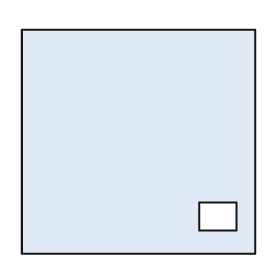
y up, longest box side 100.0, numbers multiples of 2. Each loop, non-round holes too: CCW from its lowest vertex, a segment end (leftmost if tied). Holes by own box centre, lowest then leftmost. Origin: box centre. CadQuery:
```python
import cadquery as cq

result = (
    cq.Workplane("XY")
    .moveTo(-50.0, -48.0)
    .lineTo(50.0, -48.0)
    .lineTo(50.0, 48.0)
    .lineTo(-50.0, 48.0)
    .close()
    .moveTo(26.0, -38.0)
    .lineTo(42.0, -38.0)
    .lineTo(42.0, -26.0)
    .lineTo(26.0, -26.0)
    .close()
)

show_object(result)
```